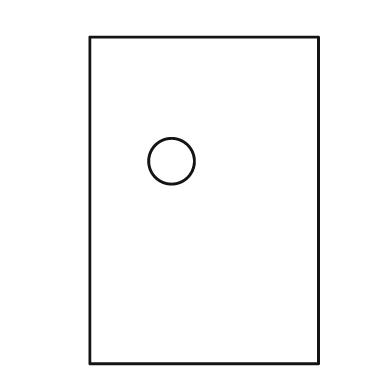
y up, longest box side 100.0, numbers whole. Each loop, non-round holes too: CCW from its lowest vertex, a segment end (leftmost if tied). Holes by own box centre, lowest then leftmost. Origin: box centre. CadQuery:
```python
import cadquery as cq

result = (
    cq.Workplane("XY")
    .moveTo(-35.0, -50.0)
    .lineTo(35.0, -50.0)
    .lineTo(35.0, 50.0)
    .lineTo(-35.0, 50.0)
    .close()
    .moveTo(-10.0, 12.0)
    .circle(7.0)
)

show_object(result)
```